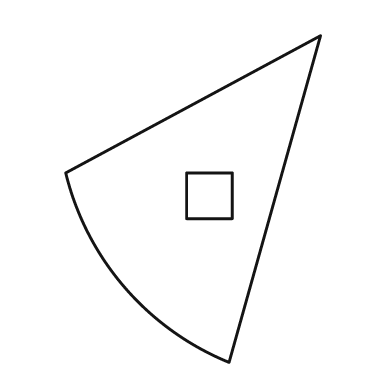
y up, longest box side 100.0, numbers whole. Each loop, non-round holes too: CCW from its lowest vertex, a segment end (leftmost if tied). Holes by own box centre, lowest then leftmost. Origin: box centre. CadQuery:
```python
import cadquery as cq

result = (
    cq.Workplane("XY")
    .moveTo(11.0, -50.0)
    .lineTo(39.0, 50.0)
    .lineTo(-39.0, 8.0)
    .threePointArc((-21.0, -27.0), (11.0, -50.0))
    .close()
    .moveTo(-2.0, -6.0)
    .lineTo(12.0, -6.0)
    .lineTo(12.0, 8.0)
    .lineTo(-2.0, 8.0)
    .close()
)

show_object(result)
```